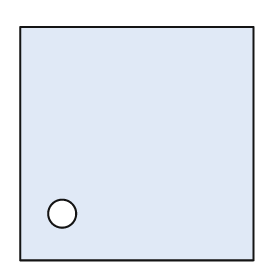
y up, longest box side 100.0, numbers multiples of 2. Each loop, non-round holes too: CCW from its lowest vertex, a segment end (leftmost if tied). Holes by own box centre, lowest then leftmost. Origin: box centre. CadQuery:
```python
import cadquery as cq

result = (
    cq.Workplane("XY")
    .moveTo(-50.0, -50.0)
    .lineTo(50.0, -50.0)
    .lineTo(50.0, 50.0)
    .lineTo(-50.0, 50.0)
    .close()
    .moveTo(-32.0, -30.0)
    .circle(6.0)
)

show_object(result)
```